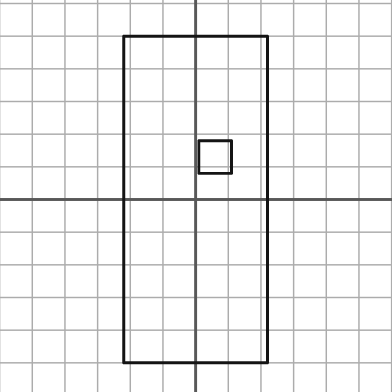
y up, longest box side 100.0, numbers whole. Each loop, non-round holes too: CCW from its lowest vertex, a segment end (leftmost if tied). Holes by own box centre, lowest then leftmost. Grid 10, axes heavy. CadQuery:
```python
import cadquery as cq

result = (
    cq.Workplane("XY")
    .moveTo(-22.0, -50.0)
    .lineTo(22.0, -50.0)
    .lineTo(22.0, 50.0)
    .lineTo(-22.0, 50.0)
    .close()
    .moveTo(1.0, 8.0)
    .lineTo(11.0, 8.0)
    .lineTo(11.0, 18.0)
    .lineTo(1.0, 18.0)
    .close()
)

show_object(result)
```